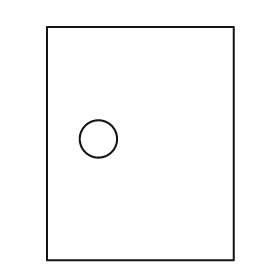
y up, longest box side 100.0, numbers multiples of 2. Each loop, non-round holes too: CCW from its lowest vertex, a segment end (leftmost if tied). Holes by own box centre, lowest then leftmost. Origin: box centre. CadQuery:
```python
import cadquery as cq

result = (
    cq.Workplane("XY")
    .moveTo(-40.0, -50.0)
    .lineTo(40.0, -50.0)
    .lineTo(40.0, 50.0)
    .lineTo(-40.0, 50.0)
    .close()
    .moveTo(-18.0, 2.0)
    .circle(8.0)
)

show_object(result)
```